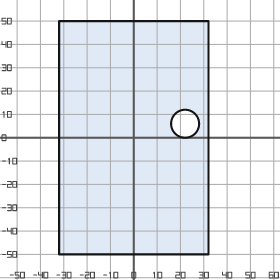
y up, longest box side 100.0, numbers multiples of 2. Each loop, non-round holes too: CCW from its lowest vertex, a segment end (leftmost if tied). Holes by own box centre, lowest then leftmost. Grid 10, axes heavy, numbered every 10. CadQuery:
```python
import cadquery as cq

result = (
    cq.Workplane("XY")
    .moveTo(-32.0, -50.0)
    .lineTo(32.0, -50.0)
    .lineTo(32.0, 50.0)
    .lineTo(-32.0, 50.0)
    .close()
    .moveTo(22.0, 6.0)
    .circle(6.0)
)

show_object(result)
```